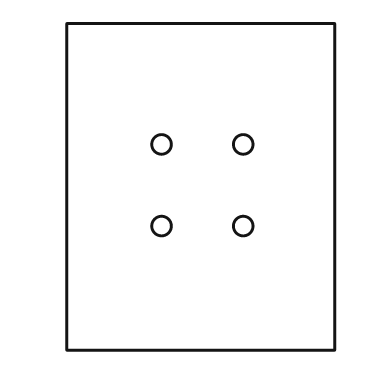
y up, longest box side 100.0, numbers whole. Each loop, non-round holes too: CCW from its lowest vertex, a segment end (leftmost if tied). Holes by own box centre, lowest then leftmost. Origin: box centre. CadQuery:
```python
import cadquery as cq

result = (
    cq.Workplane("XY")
    .moveTo(-41.0, -50.0)
    .lineTo(41.0, -50.0)
    .lineTo(41.0, 50.0)
    .lineTo(-41.0, 50.0)
    .close()
    .moveTo(-12.0, -12.0)
    .circle(3.0)
    .moveTo(13.0, -12.0)
    .circle(3.0)
    .moveTo(-12.0, 13.0)
    .circle(3.0)
    .moveTo(13.0, 13.0)
    .circle(3.0)
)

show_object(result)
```